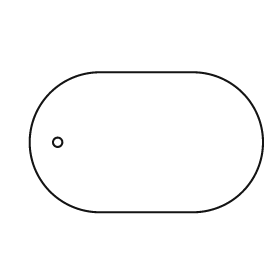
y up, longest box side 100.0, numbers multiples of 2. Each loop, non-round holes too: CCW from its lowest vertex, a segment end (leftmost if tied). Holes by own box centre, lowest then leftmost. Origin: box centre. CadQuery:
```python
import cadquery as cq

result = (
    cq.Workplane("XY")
    .moveTo(-20.0, -30.0)
    .lineTo(20.0, -30.0)
    .threePointArc((50.0, 0.0), (20.0, 30.0))
    .lineTo(-20.0, 30.0)
    .threePointArc((-50.0, 0.0), (-20.0, -30.0))
    .close()
    .moveTo(-38.0, 0.0)
    .circle(2.0)
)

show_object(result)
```